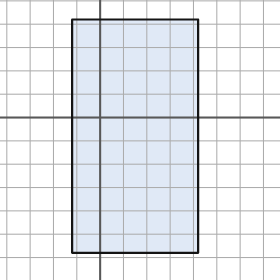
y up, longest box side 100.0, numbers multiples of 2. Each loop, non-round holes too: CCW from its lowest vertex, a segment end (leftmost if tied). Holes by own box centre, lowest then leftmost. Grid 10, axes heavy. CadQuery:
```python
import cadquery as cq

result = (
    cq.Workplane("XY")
    .moveTo(-12.0, -58.0)
    .lineTo(42.0, -58.0)
    .lineTo(42.0, 42.0)
    .lineTo(-12.0, 42.0)
    .close()
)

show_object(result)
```